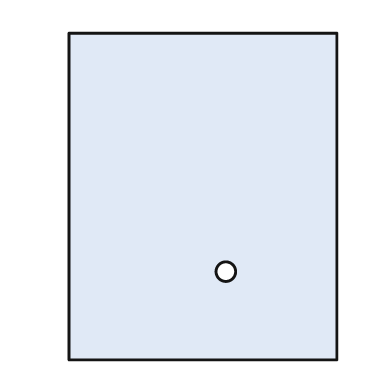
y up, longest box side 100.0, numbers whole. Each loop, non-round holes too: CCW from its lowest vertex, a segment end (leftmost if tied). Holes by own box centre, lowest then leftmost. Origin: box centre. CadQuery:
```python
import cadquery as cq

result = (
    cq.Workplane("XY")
    .moveTo(-41.0, -50.0)
    .lineTo(41.0, -50.0)
    .lineTo(41.0, 50.0)
    .lineTo(-41.0, 50.0)
    .close()
    .moveTo(7.0, -23.0)
    .circle(3.0)
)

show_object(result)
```